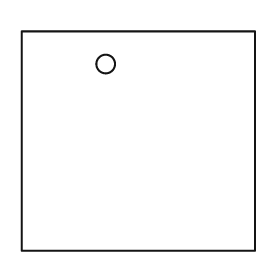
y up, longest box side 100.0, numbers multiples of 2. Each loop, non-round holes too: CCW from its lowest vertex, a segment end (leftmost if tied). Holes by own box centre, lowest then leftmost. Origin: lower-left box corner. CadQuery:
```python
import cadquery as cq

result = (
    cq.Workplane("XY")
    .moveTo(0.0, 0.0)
    .lineTo(100.0, 0.0)
    .lineTo(100.0, 94.0)
    .lineTo(0.0, 94.0)
    .close()
    .moveTo(36.0, 80.0)
    .circle(4.0)
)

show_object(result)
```